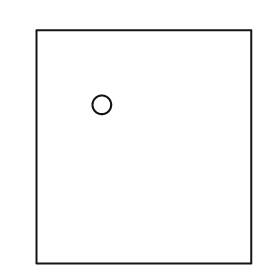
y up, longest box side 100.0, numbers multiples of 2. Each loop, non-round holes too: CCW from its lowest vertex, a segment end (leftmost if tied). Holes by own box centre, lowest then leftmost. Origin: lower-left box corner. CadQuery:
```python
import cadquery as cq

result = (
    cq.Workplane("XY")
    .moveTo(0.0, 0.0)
    .lineTo(92.0, 0.0)
    .lineTo(92.0, 100.0)
    .lineTo(0.0, 100.0)
    .close()
    .moveTo(28.0, 68.0)
    .circle(4.0)
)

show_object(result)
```